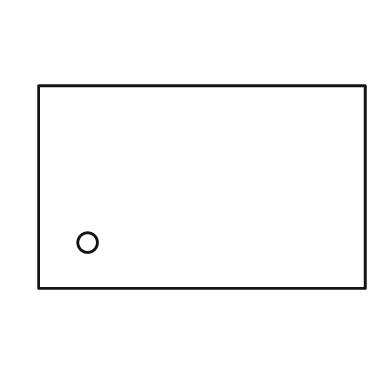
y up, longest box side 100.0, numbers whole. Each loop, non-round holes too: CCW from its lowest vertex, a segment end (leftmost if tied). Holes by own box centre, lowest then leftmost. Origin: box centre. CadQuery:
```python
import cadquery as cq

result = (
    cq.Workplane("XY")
    .moveTo(-50.0, -31.0)
    .lineTo(50.0, -31.0)
    .lineTo(50.0, 31.0)
    .lineTo(-50.0, 31.0)
    .close()
    .moveTo(-35.0, -17.0)
    .circle(3.0)
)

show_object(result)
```